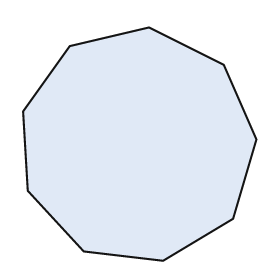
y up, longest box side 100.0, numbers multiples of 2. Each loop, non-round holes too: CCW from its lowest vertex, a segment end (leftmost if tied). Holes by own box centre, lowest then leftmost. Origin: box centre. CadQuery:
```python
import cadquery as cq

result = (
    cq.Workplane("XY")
    .moveTo(10.0, -50.0)
    .lineTo(40.0, -32.0)
    .lineTo(50.0, 2.0)
    .lineTo(36.0, 34.0)
    .lineTo(4.0, 50.0)
    .lineTo(-30.0, 42.0)
    .lineTo(-50.0, 14.0)
    .lineTo(-48.0, -20.0)
    .lineTo(-24.0, -46.0)
    .close()
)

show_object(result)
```